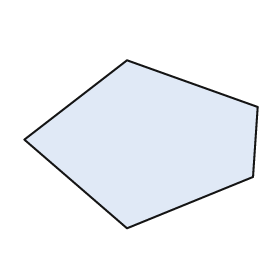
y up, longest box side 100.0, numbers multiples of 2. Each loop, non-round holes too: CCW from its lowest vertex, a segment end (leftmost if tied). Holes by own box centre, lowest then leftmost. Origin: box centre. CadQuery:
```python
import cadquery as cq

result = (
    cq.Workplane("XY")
    .moveTo(-6.0, -36.0)
    .lineTo(48.0, -14.0)
    .lineTo(50.0, 16.0)
    .lineTo(-6.0, 36.0)
    .lineTo(-50.0, 2.0)
    .close()
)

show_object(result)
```